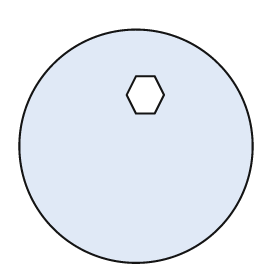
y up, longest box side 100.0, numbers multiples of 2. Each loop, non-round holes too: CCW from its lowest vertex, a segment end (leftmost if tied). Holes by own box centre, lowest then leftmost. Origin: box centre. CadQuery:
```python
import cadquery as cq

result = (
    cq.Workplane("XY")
    .moveTo(0.0, 0.0)
    .circle(50.0)
    .moveTo(0.0, 14.0)
    .lineTo(8.0, 14.0)
    .lineTo(12.0, 22.0)
    .lineTo(8.0, 30.0)
    .lineTo(0.0, 30.0)
    .lineTo(-4.0, 22.0)
    .close()
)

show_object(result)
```